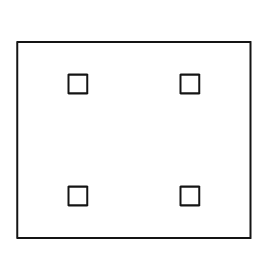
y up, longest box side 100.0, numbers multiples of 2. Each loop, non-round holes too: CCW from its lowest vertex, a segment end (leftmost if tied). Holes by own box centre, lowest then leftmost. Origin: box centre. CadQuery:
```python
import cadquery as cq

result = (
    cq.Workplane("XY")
    .moveTo(-50.0, -42.0)
    .lineTo(50.0, -42.0)
    .lineTo(50.0, 42.0)
    .lineTo(-50.0, 42.0)
    .close()
    .moveTo(-28.0, -28.0)
    .lineTo(-20.0, -28.0)
    .lineTo(-20.0, -20.0)
    .lineTo(-28.0, -20.0)
    .close()
    .moveTo(20.0, -28.0)
    .lineTo(28.0, -28.0)
    .lineTo(28.0, -20.0)
    .lineTo(20.0, -20.0)
    .close()
    .moveTo(-28.0, 20.0)
    .lineTo(-20.0, 20.0)
    .lineTo(-20.0, 28.0)
    .lineTo(-28.0, 28.0)
    .close()
    .moveTo(20.0, 20.0)
    .lineTo(28.0, 20.0)
    .lineTo(28.0, 28.0)
    .lineTo(20.0, 28.0)
    .close()
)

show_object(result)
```